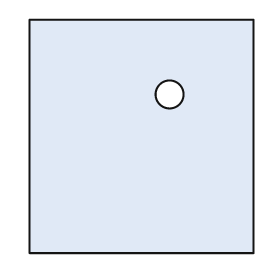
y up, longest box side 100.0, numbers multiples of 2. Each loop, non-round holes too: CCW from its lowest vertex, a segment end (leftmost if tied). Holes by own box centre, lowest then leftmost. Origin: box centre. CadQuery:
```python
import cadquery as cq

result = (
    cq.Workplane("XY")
    .moveTo(-48.0, -50.0)
    .lineTo(48.0, -50.0)
    .lineTo(48.0, 50.0)
    .lineTo(-48.0, 50.0)
    .close()
    .moveTo(12.0, 18.0)
    .circle(6.0)
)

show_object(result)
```